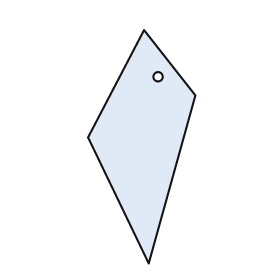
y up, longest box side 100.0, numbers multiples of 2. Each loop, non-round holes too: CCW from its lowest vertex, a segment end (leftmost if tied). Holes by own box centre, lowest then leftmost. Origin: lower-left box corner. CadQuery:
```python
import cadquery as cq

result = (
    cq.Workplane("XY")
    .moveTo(26.0, 0.0)
    .lineTo(46.0, 72.0)
    .lineTo(24.0, 100.0)
    .lineTo(0.0, 54.0)
    .close()
    .moveTo(30.0, 80.0)
    .circle(2.0)
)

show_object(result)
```